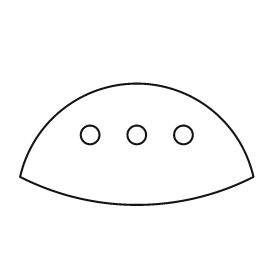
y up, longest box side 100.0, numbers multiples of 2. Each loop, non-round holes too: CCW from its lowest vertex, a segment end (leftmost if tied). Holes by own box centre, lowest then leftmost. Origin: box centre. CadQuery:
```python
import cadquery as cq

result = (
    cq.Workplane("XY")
    .moveTo(-50.0, -14.0)
    .threePointArc((0.0, -26.0), (50.0, -14.0))
    .threePointArc((0.0, 26.0), (-50.0, -14.0))
    .close()
    .moveTo(-20.0, 4.0)
    .circle(4.0)
    .moveTo(0.0, 4.0)
    .circle(4.0)
    .moveTo(20.0, 4.0)
    .circle(4.0)
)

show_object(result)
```